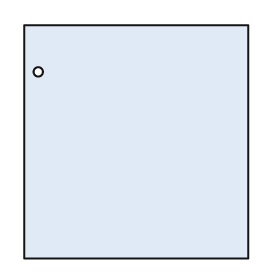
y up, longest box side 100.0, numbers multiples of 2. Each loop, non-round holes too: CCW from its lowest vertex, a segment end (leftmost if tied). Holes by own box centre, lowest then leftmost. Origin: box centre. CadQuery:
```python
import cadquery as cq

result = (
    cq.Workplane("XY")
    .moveTo(-48.0, -50.0)
    .lineTo(48.0, -50.0)
    .lineTo(48.0, 50.0)
    .lineTo(-48.0, 50.0)
    .close()
    .moveTo(-42.0, 30.0)
    .circle(2.0)
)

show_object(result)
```